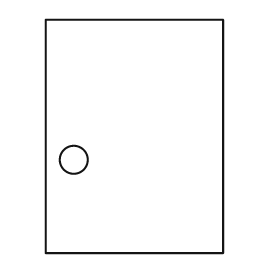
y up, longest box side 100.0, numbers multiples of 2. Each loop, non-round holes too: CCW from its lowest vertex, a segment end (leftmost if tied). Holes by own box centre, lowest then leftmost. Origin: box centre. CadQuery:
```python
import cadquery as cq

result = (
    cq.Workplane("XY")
    .moveTo(-38.0, -50.0)
    .lineTo(38.0, -50.0)
    .lineTo(38.0, 50.0)
    .lineTo(-38.0, 50.0)
    .close()
    .moveTo(-26.0, -10.0)
    .circle(6.0)
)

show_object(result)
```